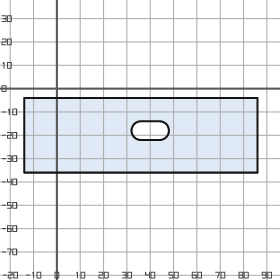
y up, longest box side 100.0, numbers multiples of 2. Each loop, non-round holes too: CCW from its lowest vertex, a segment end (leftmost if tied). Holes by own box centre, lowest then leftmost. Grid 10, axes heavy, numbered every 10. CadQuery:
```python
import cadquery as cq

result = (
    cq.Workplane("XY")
    .moveTo(-14.0, -36.0)
    .lineTo(86.0, -36.0)
    .lineTo(86.0, -4.0)
    .lineTo(-14.0, -4.0)
    .close()
    .moveTo(36.0, -22.0)
    .lineTo(44.0, -22.0)
    .threePointArc((48.0, -18.0), (44.0, -14.0))
    .lineTo(36.0, -14.0)
    .threePointArc((32.0, -18.0), (36.0, -22.0))
    .close()
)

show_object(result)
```